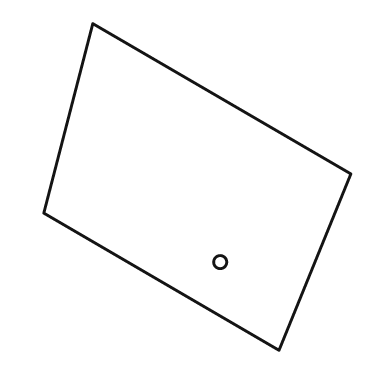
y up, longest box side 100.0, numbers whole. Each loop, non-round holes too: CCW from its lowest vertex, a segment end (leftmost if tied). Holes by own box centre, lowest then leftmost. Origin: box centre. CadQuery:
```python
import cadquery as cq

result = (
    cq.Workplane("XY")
    .moveTo(25.0, -50.0)
    .lineTo(47.0, 4.0)
    .lineTo(-32.0, 50.0)
    .lineTo(-47.0, -8.0)
    .close()
    .moveTo(7.0, -23.0)
    .circle(2.0)
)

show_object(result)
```